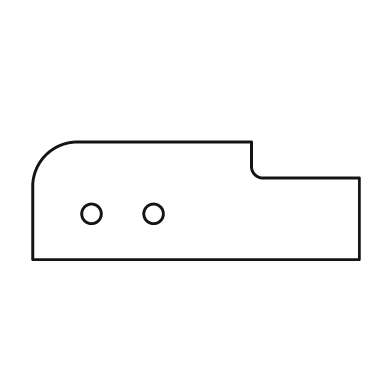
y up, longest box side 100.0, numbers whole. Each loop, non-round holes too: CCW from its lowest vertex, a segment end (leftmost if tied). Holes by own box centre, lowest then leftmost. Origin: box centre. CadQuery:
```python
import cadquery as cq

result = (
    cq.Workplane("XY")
    .moveTo(-50.0, -18.0)
    .lineTo(50.0, -18.0)
    .lineTo(50.0, 7.0)
    .lineTo(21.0, 7.0)
    .threePointArc((18.0, 8.0), (17.0, 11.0))
    .lineTo(17.0, 18.0)
    .lineTo(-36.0, 18.0)
    .threePointArc((-46.0, 14.0), (-50.0, 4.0))
    .close()
    .moveTo(-32.0, -4.0)
    .circle(3.0)
    .moveTo(-13.0, -4.0)
    .circle(3.0)
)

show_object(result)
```